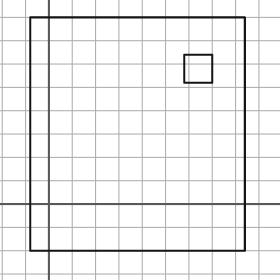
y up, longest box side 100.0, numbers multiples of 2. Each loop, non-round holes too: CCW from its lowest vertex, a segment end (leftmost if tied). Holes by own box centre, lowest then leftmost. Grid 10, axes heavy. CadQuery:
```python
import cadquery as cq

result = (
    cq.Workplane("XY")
    .moveTo(-8.0, -20.0)
    .lineTo(84.0, -20.0)
    .lineTo(84.0, 80.0)
    .lineTo(-8.0, 80.0)
    .close()
    .moveTo(58.0, 52.0)
    .lineTo(70.0, 52.0)
    .lineTo(70.0, 64.0)
    .lineTo(58.0, 64.0)
    .close()
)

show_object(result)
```